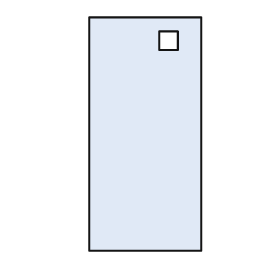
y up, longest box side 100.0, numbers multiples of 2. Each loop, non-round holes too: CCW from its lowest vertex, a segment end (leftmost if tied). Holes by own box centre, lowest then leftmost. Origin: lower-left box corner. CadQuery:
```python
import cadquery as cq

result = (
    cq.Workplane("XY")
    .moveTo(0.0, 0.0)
    .lineTo(48.0, 0.0)
    .lineTo(48.0, 100.0)
    .lineTo(0.0, 100.0)
    .close()
    .moveTo(30.0, 86.0)
    .lineTo(38.0, 86.0)
    .lineTo(38.0, 94.0)
    .lineTo(30.0, 94.0)
    .close()
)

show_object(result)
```